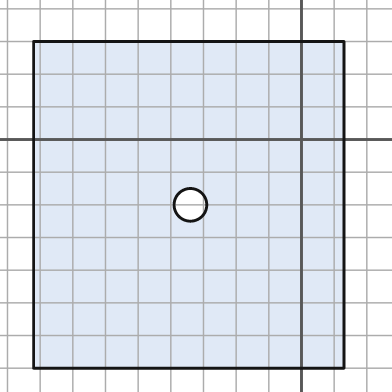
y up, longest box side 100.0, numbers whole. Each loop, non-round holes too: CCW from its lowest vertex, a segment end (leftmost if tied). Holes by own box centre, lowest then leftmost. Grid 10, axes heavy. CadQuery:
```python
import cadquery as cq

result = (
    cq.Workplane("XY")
    .moveTo(-82.0, -70.0)
    .lineTo(13.0, -70.0)
    .lineTo(13.0, 30.0)
    .lineTo(-82.0, 30.0)
    .close()
    .moveTo(-34.0, -20.0)
    .circle(5.0)
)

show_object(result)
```